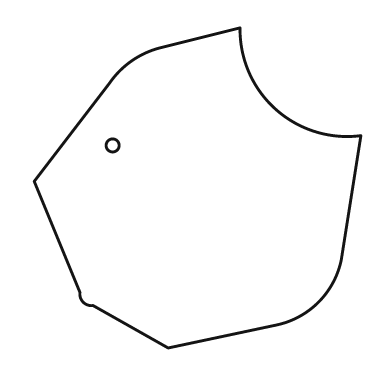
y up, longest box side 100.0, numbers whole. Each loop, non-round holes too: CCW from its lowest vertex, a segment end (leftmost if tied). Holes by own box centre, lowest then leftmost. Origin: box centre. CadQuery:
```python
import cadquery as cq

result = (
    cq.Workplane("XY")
    .moveTo(-9.0, -49.0)
    .lineTo(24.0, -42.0)
    .threePointArc((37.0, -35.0), (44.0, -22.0))
    .lineTo(50.0, 16.0)
    .threePointArc((24.0, 24.0), (13.0, 49.0))
    .lineTo(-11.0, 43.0)
    .threePointArc((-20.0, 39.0), (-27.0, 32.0))
    .lineTo(-50.0, 2.0)
    .lineTo(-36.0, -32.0)
    .threePointArc((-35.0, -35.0), (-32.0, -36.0))
    .close()
    .moveTo(-26.0, 13.0)
    .circle(2.0)
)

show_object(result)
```